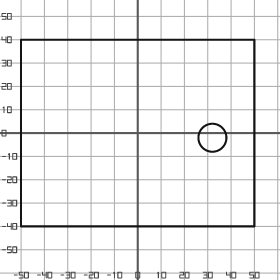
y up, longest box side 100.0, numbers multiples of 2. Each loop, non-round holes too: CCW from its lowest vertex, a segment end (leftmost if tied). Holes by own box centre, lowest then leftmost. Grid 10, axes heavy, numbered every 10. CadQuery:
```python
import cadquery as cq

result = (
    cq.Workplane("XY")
    .moveTo(-50.0, -40.0)
    .lineTo(50.0, -40.0)
    .lineTo(50.0, 40.0)
    .lineTo(-50.0, 40.0)
    .close()
    .moveTo(32.0, -2.0)
    .circle(6.0)
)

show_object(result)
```